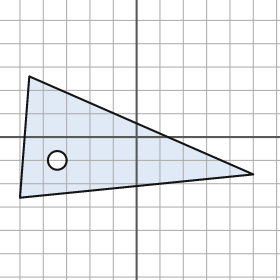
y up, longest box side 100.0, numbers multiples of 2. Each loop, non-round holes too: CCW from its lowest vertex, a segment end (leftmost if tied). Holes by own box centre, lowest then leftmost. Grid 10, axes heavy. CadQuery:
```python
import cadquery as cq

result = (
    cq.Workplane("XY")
    .moveTo(-50.0, -26.0)
    .lineTo(50.0, -16.0)
    .lineTo(-46.0, 26.0)
    .close()
    .moveTo(-34.0, -10.0)
    .circle(4.0)
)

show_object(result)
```